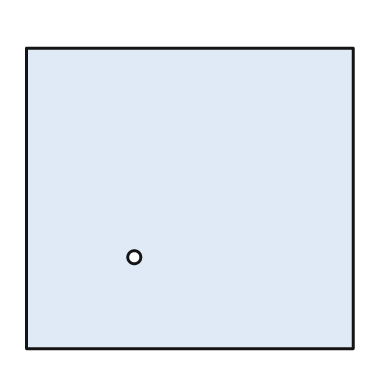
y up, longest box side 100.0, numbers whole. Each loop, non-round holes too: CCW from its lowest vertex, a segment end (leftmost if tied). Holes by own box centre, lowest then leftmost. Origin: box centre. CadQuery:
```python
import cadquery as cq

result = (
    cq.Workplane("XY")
    .moveTo(-50.0, -46.0)
    .lineTo(50.0, -46.0)
    .lineTo(50.0, 46.0)
    .lineTo(-50.0, 46.0)
    .close()
    .moveTo(-17.0, -18.0)
    .circle(2.0)
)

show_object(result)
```